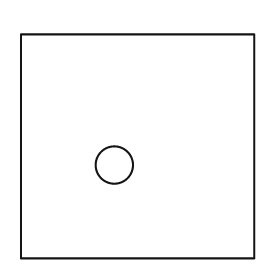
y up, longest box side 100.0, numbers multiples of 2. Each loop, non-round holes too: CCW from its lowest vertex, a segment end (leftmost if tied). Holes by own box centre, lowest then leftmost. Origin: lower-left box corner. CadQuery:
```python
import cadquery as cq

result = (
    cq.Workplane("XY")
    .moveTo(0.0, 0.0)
    .lineTo(100.0, 0.0)
    .lineTo(100.0, 96.0)
    .lineTo(0.0, 96.0)
    .close()
    .moveTo(40.0, 40.0)
    .circle(8.0)
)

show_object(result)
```